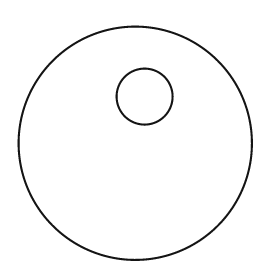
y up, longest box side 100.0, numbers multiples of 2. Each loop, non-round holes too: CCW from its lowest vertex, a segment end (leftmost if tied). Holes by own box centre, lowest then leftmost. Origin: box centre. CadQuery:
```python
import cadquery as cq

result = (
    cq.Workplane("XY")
    .moveTo(0.0, 0.0)
    .circle(50.0)
    .moveTo(4.0, 20.0)
    .circle(12.0)
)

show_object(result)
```